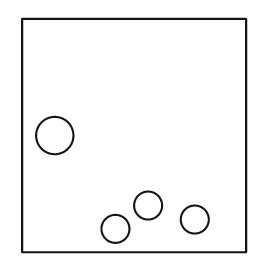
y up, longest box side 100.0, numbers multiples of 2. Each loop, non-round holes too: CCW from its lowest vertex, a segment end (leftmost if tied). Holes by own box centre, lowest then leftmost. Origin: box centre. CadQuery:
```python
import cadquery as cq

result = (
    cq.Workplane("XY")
    .moveTo(-48.0, -50.0)
    .lineTo(48.0, -50.0)
    .lineTo(48.0, 50.0)
    .lineTo(-48.0, 50.0)
    .close()
    .moveTo(-8.0, -40.0)
    .circle(6.0)
    .moveTo(26.0, -36.0)
    .circle(6.0)
    .moveTo(6.0, -30.0)
    .circle(6.0)
    .moveTo(-34.0, 0.0)
    .circle(8.0)
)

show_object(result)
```